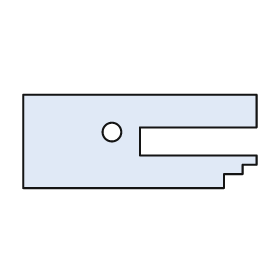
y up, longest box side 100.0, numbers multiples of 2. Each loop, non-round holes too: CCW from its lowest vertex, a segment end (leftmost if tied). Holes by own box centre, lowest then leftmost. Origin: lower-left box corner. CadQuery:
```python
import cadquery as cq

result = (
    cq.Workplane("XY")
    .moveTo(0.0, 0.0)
    .lineTo(86.0, 0.0)
    .lineTo(86.0, 6.0)
    .lineTo(94.0, 6.0)
    .lineTo(94.0, 10.0)
    .lineTo(100.0, 10.0)
    .lineTo(100.0, 14.0)
    .lineTo(50.0, 14.0)
    .lineTo(50.0, 26.0)
    .lineTo(100.0, 26.0)
    .lineTo(100.0, 40.0)
    .lineTo(0.0, 40.0)
    .close()
    .moveTo(38.0, 24.0)
    .circle(4.0)
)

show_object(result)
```